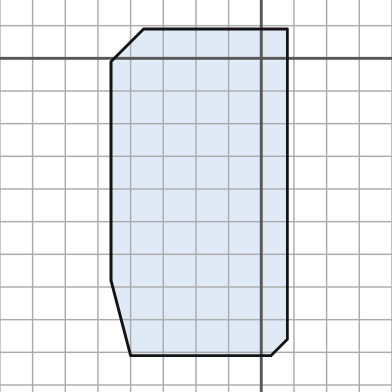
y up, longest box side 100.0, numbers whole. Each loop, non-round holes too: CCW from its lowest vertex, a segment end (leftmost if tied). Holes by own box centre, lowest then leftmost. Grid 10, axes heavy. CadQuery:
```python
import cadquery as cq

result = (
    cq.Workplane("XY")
    .moveTo(-40.0, -91.0)
    .lineTo(3.0, -91.0)
    .lineTo(8.0, -86.0)
    .lineTo(8.0, 9.0)
    .lineTo(-36.0, 9.0)
    .lineTo(-46.0, -1.0)
    .lineTo(-46.0, -68.0)
    .close()
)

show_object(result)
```